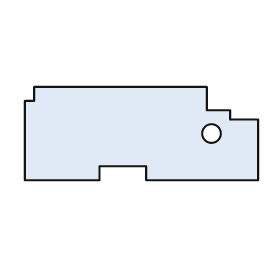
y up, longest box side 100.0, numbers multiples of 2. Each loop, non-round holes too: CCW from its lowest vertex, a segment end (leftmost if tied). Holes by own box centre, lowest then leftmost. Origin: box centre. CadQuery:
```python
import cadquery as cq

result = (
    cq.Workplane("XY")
    .moveTo(-50.0, -20.0)
    .lineTo(-18.0, -20.0)
    .lineTo(-18.0, -14.0)
    .lineTo(2.0, -14.0)
    .lineTo(2.0, -20.0)
    .lineTo(50.0, -20.0)
    .lineTo(50.0, 6.0)
    .lineTo(38.0, 6.0)
    .lineTo(38.0, 10.0)
    .lineTo(28.0, 10.0)
    .lineTo(28.0, 20.0)
    .lineTo(-46.0, 20.0)
    .lineTo(-46.0, 14.0)
    .lineTo(-50.0, 14.0)
    .close()
    .moveTo(30.0, 0.0)
    .circle(4.0)
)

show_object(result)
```